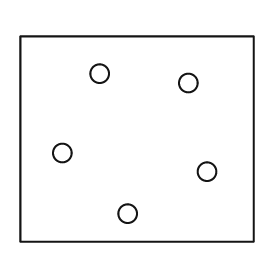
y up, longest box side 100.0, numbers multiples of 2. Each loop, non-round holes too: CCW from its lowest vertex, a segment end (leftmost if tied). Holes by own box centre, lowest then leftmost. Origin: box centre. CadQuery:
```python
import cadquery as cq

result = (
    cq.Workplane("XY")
    .moveTo(-50.0, -44.0)
    .lineTo(50.0, -44.0)
    .lineTo(50.0, 44.0)
    .lineTo(-50.0, 44.0)
    .close()
    .moveTo(-4.0, -32.0)
    .circle(4.0)
    .moveTo(30.0, -14.0)
    .circle(4.0)
    .moveTo(-32.0, -6.0)
    .circle(4.0)
    .moveTo(22.0, 24.0)
    .circle(4.0)
    .moveTo(-16.0, 28.0)
    .circle(4.0)
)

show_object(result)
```